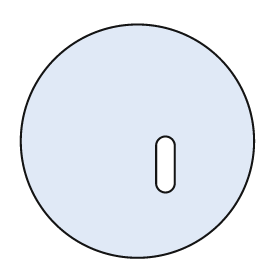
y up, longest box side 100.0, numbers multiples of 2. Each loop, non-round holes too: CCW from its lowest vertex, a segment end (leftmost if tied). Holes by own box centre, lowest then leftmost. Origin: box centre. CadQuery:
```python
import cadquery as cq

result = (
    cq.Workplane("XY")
    .moveTo(0.0, 0.0)
    .circle(50.0)
    .moveTo(8.0, -18.0)
    .threePointArc((12.0, -22.0), (16.0, -18.0))
    .lineTo(16.0, -2.0)
    .threePointArc((12.0, 2.0), (8.0, -2.0))
    .close()
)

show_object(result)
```